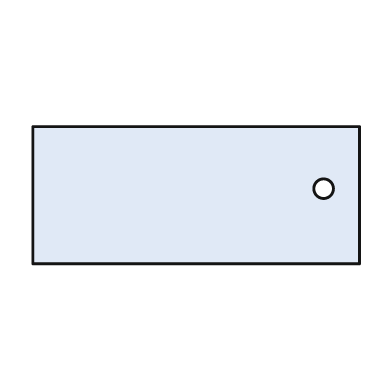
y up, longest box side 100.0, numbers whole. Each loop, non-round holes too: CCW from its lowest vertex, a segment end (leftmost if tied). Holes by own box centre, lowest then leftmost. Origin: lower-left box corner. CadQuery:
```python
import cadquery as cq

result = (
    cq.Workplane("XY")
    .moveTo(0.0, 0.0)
    .lineTo(100.0, 0.0)
    .lineTo(100.0, 42.0)
    .lineTo(0.0, 42.0)
    .close()
    .moveTo(89.0, 23.0)
    .circle(3.0)
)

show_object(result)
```